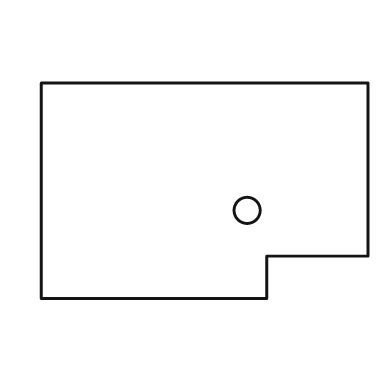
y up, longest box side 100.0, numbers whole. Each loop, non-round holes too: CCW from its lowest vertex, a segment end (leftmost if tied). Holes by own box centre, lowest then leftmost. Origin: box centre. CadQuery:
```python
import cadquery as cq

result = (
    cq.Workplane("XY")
    .moveTo(-50.0, -33.0)
    .lineTo(19.0, -33.0)
    .lineTo(19.0, -20.0)
    .lineTo(50.0, -20.0)
    .lineTo(50.0, 33.0)
    .lineTo(-50.0, 33.0)
    .close()
    .moveTo(13.0, -6.0)
    .circle(4.0)
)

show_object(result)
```